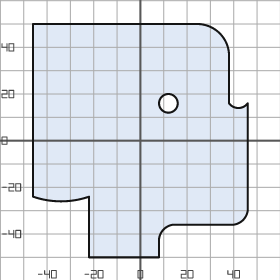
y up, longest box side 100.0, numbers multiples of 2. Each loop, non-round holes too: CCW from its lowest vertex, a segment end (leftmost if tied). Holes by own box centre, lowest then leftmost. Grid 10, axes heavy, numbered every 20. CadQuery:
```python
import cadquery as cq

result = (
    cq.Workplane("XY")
    .moveTo(-22.0, -50.0)
    .lineTo(8.0, -50.0)
    .lineTo(8.0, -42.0)
    .threePointArc((10.0, -38.0), (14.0, -36.0))
    .lineTo(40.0, -36.0)
    .threePointArc((44.0, -34.0), (46.0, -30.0))
    .lineTo(46.0, 16.0)
    .threePointArc((42.0, 14.0), (38.0, 16.0))
    .lineTo(38.0, 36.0)
    .threePointArc((34.0, 46.0), (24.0, 50.0))
    .lineTo(-46.0, 50.0)
    .lineTo(-46.0, -24.0)
    .threePointArc((-34.0, -26.0), (-22.0, -24.0))
    .close()
    .moveTo(12.0, 16.0)
    .circle(4.0)
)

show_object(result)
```